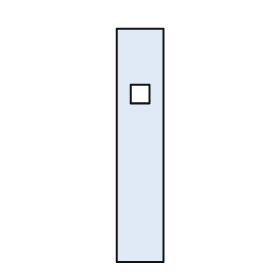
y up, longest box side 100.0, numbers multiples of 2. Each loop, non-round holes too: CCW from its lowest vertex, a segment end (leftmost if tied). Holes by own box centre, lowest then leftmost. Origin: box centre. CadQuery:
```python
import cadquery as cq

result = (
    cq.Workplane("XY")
    .moveTo(-10.0, -50.0)
    .lineTo(10.0, -50.0)
    .lineTo(10.0, 50.0)
    .lineTo(-10.0, 50.0)
    .close()
    .moveTo(-4.0, 18.0)
    .lineTo(4.0, 18.0)
    .lineTo(4.0, 26.0)
    .lineTo(-4.0, 26.0)
    .close()
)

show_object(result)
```